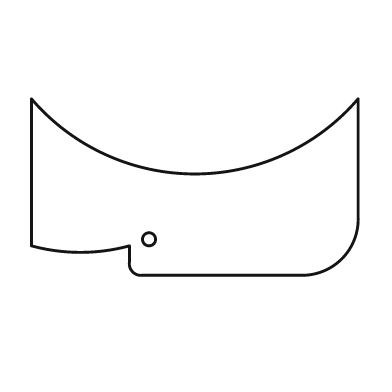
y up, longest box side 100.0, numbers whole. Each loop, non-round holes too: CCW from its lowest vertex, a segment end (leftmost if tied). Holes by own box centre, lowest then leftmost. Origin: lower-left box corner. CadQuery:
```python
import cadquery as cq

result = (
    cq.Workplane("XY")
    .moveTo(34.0, 0.0)
    .lineTo(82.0, 0.0)
    .threePointArc((95.0, 5.0), (100.0, 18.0))
    .lineTo(100.0, 54.0)
    .threePointArc((50.0, 31.0), (0.0, 54.0))
    .lineTo(0.0, 9.0)
    .threePointArc((15.0, 7.0), (30.0, 9.0))
    .lineTo(30.0, 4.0)
    .threePointArc((31.0, 1.0), (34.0, 0.0))
    .close()
    .moveTo(36.0, 11.0)
    .circle(2.0)
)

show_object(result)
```